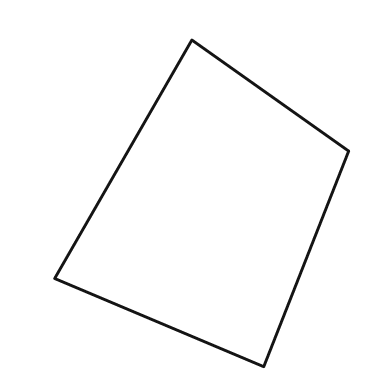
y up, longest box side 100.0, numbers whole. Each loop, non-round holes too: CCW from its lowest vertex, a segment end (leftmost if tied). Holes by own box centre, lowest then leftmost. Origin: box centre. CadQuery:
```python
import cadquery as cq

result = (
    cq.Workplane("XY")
    .moveTo(19.0, -50.0)
    .lineTo(45.0, 16.0)
    .lineTo(-3.0, 50.0)
    .lineTo(-45.0, -23.0)
    .close()
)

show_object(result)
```